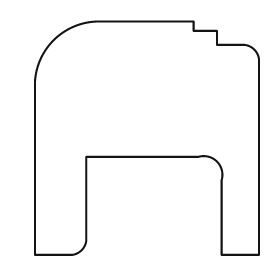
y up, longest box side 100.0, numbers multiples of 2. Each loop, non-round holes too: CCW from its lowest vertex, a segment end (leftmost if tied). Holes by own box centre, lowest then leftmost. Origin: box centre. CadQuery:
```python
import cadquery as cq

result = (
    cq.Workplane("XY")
    .moveTo(-48.0, -50.0)
    .lineTo(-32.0, -50.0)
    .threePointArc((-28.0, -48.0), (-26.0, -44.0))
    .lineTo(-26.0, -8.0)
    .lineTo(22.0, -8.0)
    .threePointArc((30.0, -10.0), (32.0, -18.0))
    .lineTo(32.0, -50.0)
    .lineTo(48.0, -50.0)
    .lineTo(48.0, 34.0)
    .threePointArc((46.0, 38.0), (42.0, 40.0))
    .lineTo(30.0, 40.0)
    .lineTo(30.0, 46.0)
    .lineTo(20.0, 46.0)
    .lineTo(20.0, 50.0)
    .lineTo(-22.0, 50.0)
    .threePointArc((-40.0, 42.0), (-48.0, 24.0))
    .close()
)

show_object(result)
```